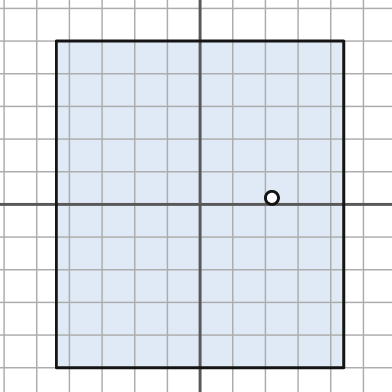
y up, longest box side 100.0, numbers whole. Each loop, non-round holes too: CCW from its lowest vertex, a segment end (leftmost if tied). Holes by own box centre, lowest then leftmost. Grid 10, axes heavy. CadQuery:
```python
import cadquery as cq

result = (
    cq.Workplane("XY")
    .moveTo(-44.0, -50.0)
    .lineTo(44.0, -50.0)
    .lineTo(44.0, 50.0)
    .lineTo(-44.0, 50.0)
    .close()
    .moveTo(22.0, 2.0)
    .circle(2.0)
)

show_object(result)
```